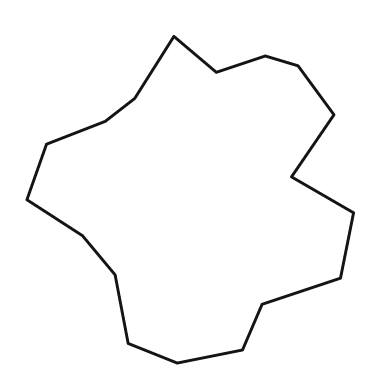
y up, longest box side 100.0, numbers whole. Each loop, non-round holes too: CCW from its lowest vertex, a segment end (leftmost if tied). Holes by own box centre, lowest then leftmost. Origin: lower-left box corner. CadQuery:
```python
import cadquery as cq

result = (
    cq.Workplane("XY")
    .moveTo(46.0, 0.0)
    .lineTo(66.0, 4.0)
    .lineTo(72.0, 18.0)
    .lineTo(96.0, 26.0)
    .lineTo(100.0, 46.0)
    .lineTo(81.0, 57.0)
    .lineTo(94.0, 76.0)
    .lineTo(83.0, 91.0)
    .lineTo(73.0, 94.0)
    .lineTo(58.0, 89.0)
    .lineTo(45.0, 100.0)
    .lineTo(33.0, 81.0)
    .lineTo(24.0, 74.0)
    .lineTo(6.0, 67.0)
    .lineTo(0.0, 50.0)
    .lineTo(17.0, 39.0)
    .lineTo(27.0, 27.0)
    .lineTo(31.0, 6.0)
    .close()
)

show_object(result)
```